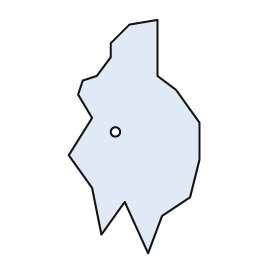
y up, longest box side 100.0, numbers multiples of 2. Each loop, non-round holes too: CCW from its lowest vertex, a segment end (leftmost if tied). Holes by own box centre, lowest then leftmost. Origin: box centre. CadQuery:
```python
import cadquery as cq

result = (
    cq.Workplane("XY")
    .moveTo(6.0, -50.0)
    .lineTo(12.0, -34.0)
    .lineTo(24.0, -26.0)
    .lineTo(28.0, -10.0)
    .lineTo(28.0, 6.0)
    .lineTo(18.0, 20.0)
    .lineTo(10.0, 26.0)
    .lineTo(10.0, 50.0)
    .lineTo(-2.0, 48.0)
    .lineTo(-10.0, 40.0)
    .lineTo(-10.0, 34.0)
    .lineTo(-16.0, 26.0)
    .lineTo(-22.0, 24.0)
    .lineTo(-24.0, 18.0)
    .lineTo(-18.0, 8.0)
    .lineTo(-28.0, -8.0)
    .lineTo(-18.0, -22.0)
    .lineTo(-14.0, -42.0)
    .lineTo(-4.0, -28.0)
    .close()
    .moveTo(-8.0, 2.0)
    .circle(2.0)
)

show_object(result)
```